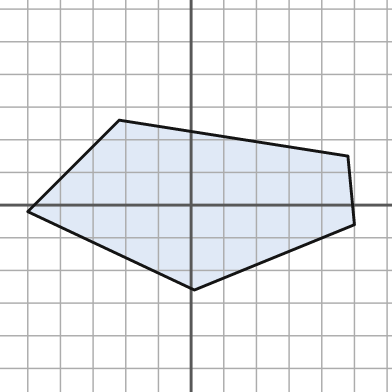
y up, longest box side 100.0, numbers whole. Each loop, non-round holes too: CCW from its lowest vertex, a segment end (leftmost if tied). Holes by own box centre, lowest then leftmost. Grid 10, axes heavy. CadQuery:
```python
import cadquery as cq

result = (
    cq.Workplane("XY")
    .moveTo(1.0, -26.0)
    .lineTo(50.0, -6.0)
    .lineTo(48.0, 15.0)
    .lineTo(-22.0, 26.0)
    .lineTo(-50.0, -2.0)
    .close()
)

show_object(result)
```